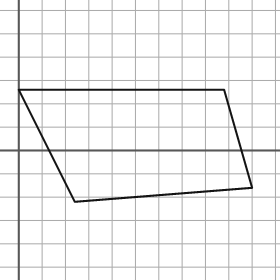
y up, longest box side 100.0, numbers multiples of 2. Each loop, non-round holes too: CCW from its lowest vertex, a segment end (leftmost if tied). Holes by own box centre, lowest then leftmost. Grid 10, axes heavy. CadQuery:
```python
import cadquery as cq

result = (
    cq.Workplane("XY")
    .moveTo(24.0, -22.0)
    .lineTo(100.0, -16.0)
    .lineTo(88.0, 26.0)
    .lineTo(0.0, 26.0)
    .close()
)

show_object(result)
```